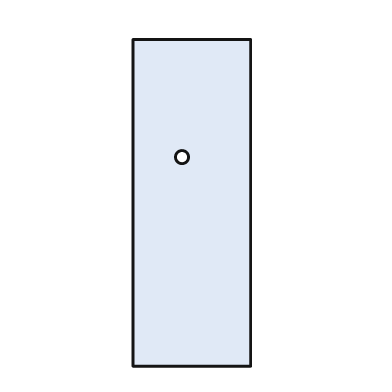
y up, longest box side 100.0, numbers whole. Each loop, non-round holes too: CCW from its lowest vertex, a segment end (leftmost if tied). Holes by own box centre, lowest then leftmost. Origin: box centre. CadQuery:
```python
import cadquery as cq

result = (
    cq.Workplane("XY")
    .moveTo(-18.0, -50.0)
    .lineTo(18.0, -50.0)
    .lineTo(18.0, 50.0)
    .lineTo(-18.0, 50.0)
    .close()
    .moveTo(-3.0, 14.0)
    .circle(2.0)
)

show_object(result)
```